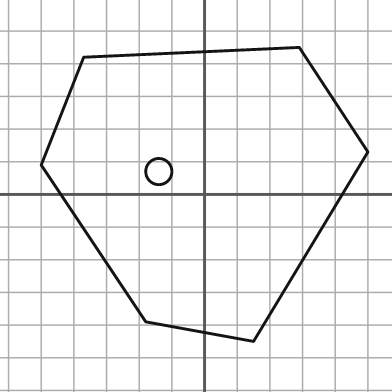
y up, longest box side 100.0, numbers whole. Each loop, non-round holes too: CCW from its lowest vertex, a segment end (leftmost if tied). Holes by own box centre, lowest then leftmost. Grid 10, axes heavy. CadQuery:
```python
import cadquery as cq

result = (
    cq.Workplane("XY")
    .moveTo(15.0, -45.0)
    .lineTo(50.0, 13.0)
    .lineTo(29.0, 45.0)
    .lineTo(-37.0, 42.0)
    .lineTo(-50.0, 9.0)
    .lineTo(-18.0, -39.0)
    .close()
    .moveTo(-14.0, 7.0)
    .circle(4.0)
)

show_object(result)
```